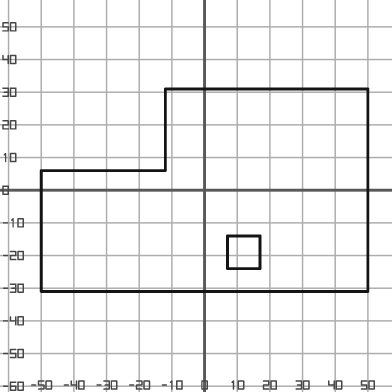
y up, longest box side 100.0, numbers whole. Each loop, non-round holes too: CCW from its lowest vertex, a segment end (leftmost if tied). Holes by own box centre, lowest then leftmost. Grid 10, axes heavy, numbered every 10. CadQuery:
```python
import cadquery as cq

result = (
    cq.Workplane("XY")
    .moveTo(-50.0, -31.0)
    .lineTo(50.0, -31.0)
    .lineTo(50.0, 31.0)
    .lineTo(-12.0, 31.0)
    .lineTo(-12.0, 6.0)
    .lineTo(-50.0, 6.0)
    .close()
    .moveTo(7.0, -24.0)
    .lineTo(17.0, -24.0)
    .lineTo(17.0, -14.0)
    .lineTo(7.0, -14.0)
    .close()
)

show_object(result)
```